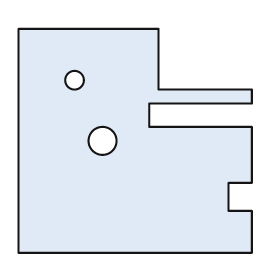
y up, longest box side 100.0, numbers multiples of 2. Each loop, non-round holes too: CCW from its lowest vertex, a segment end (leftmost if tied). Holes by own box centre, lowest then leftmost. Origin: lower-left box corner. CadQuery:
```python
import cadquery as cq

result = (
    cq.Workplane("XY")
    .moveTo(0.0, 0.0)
    .lineTo(100.0, 0.0)
    .lineTo(100.0, 18.0)
    .lineTo(90.0, 18.0)
    .lineTo(90.0, 30.0)
    .lineTo(100.0, 30.0)
    .lineTo(100.0, 54.0)
    .lineTo(56.0, 54.0)
    .lineTo(56.0, 64.0)
    .lineTo(100.0, 64.0)
    .lineTo(100.0, 70.0)
    .lineTo(60.0, 70.0)
    .lineTo(60.0, 96.0)
    .lineTo(0.0, 96.0)
    .close()
    .moveTo(36.0, 48.0)
    .circle(6.0)
    .moveTo(24.0, 74.0)
    .circle(4.0)
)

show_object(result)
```